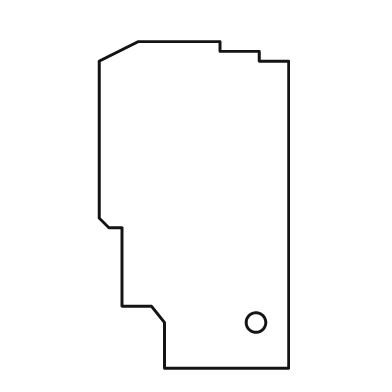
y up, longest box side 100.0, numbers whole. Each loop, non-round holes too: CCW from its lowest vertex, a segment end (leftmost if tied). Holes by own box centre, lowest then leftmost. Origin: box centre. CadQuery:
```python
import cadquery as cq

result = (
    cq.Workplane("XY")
    .moveTo(-9.0, -50.0)
    .lineTo(29.0, -50.0)
    .lineTo(29.0, 44.0)
    .lineTo(20.0, 44.0)
    .lineTo(20.0, 47.0)
    .lineTo(8.0, 47.0)
    .lineTo(8.0, 50.0)
    .lineTo(-17.0, 50.0)
    .lineTo(-29.0, 44.0)
    .lineTo(-29.0, -4.0)
    .lineTo(-26.0, -7.0)
    .lineTo(-22.0, -7.0)
    .lineTo(-22.0, -31.0)
    .lineTo(-13.0, -31.0)
    .lineTo(-9.0, -36.0)
    .close()
    .moveTo(19.0, -36.0)
    .circle(3.0)
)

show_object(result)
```